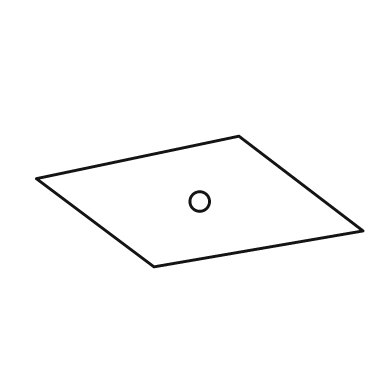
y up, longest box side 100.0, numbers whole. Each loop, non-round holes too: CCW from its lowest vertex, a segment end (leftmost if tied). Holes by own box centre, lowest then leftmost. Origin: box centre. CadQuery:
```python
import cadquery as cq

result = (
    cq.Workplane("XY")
    .moveTo(-14.0, -20.0)
    .lineTo(50.0, -9.0)
    .lineTo(12.0, 20.0)
    .lineTo(-50.0, 7.0)
    .close()
    .moveTo(0.0, 0.0)
    .circle(3.0)
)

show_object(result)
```